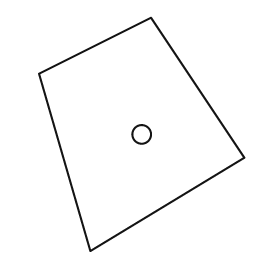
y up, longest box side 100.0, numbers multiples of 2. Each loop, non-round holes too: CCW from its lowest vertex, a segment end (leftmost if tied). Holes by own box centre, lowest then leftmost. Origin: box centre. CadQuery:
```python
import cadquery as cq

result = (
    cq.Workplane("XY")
    .moveTo(-22.0, -50.0)
    .lineTo(44.0, -10.0)
    .lineTo(4.0, 50.0)
    .lineTo(-44.0, 26.0)
    .close()
    .moveTo(0.0, 0.0)
    .circle(4.0)
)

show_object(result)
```